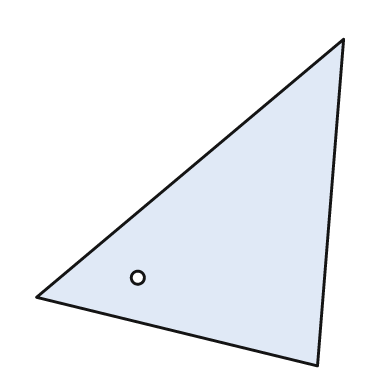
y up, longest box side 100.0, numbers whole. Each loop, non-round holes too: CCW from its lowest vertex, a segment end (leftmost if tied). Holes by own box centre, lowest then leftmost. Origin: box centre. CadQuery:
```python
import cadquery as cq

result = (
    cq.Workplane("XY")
    .moveTo(39.0, -50.0)
    .lineTo(47.0, 50.0)
    .lineTo(-47.0, -29.0)
    .close()
    .moveTo(-16.0, -23.0)
    .circle(2.0)
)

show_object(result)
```